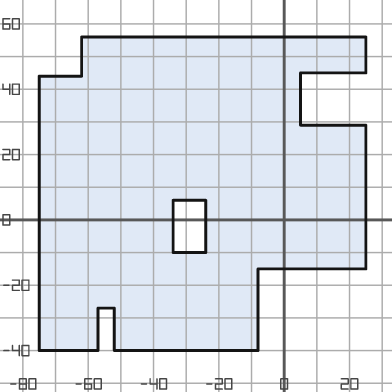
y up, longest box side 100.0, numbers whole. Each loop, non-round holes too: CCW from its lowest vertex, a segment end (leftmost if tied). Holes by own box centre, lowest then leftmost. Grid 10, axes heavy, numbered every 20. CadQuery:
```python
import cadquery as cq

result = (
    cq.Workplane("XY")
    .moveTo(-75.0, -40.0)
    .lineTo(-57.0, -40.0)
    .lineTo(-57.0, -27.0)
    .lineTo(-52.0, -27.0)
    .lineTo(-52.0, -40.0)
    .lineTo(-8.0, -40.0)
    .lineTo(-8.0, -15.0)
    .lineTo(25.0, -15.0)
    .lineTo(25.0, 29.0)
    .lineTo(5.0, 29.0)
    .lineTo(5.0, 45.0)
    .lineTo(25.0, 45.0)
    .lineTo(25.0, 56.0)
    .lineTo(-62.0, 56.0)
    .lineTo(-62.0, 44.0)
    .lineTo(-75.0, 44.0)
    .close()
    .moveTo(-34.0, -10.0)
    .lineTo(-24.0, -10.0)
    .lineTo(-24.0, 6.0)
    .lineTo(-34.0, 6.0)
    .close()
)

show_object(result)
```